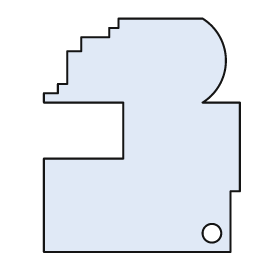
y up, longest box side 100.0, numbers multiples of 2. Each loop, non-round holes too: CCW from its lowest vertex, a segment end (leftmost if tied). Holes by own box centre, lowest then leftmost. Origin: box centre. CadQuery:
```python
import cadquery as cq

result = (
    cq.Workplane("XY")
    .moveTo(-42.0, -50.0)
    .lineTo(38.0, -50.0)
    .lineTo(38.0, -24.0)
    .lineTo(42.0, -24.0)
    .lineTo(42.0, 14.0)
    .lineTo(26.0, 14.0)
    .threePointArc((36.0, 32.0), (26.0, 50.0))
    .lineTo(-10.0, 50.0)
    .lineTo(-10.0, 46.0)
    .lineTo(-14.0, 46.0)
    .lineTo(-14.0, 42.0)
    .lineTo(-26.0, 42.0)
    .lineTo(-26.0, 36.0)
    .lineTo(-32.0, 36.0)
    .lineTo(-32.0, 22.0)
    .lineTo(-36.0, 22.0)
    .lineTo(-36.0, 18.0)
    .lineTo(-42.0, 18.0)
    .lineTo(-42.0, 14.0)
    .lineTo(-8.0, 14.0)
    .lineTo(-8.0, -10.0)
    .lineTo(-42.0, -10.0)
    .close()
    .moveTo(30.0, -42.0)
    .circle(4.0)
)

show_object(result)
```